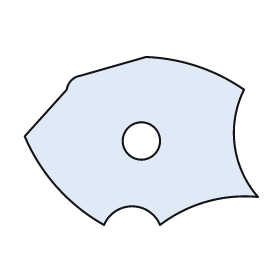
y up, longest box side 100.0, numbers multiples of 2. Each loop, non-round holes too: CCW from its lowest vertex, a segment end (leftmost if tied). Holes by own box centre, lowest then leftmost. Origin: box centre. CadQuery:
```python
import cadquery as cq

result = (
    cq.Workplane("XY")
    .moveTo(-16.0, -36.0)
    .threePointArc((-4.0, -28.0), (8.0, -36.0))
    .threePointArc((28.0, -26.0), (50.0, -24.0))
    .threePointArc((40.0, -2.0), (44.0, 22.0))
    .threePointArc((24.0, 32.0), (2.0, 36.0))
    .lineTo(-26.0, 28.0)
    .threePointArc((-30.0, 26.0), (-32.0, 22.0))
    .lineTo(-50.0, 2.0)
    .threePointArc((-36.0, -20.0), (-16.0, -36.0))
    .close()
    .moveTo(0.0, 0.0)
    .circle(8.0)
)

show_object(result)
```